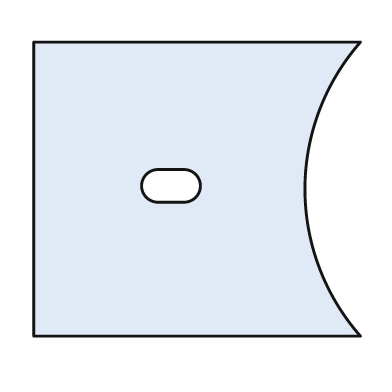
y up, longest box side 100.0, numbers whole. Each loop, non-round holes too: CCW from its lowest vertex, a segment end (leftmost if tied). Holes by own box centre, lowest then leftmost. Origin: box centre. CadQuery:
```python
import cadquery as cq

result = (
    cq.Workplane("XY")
    .moveTo(-50.0, -45.0)
    .lineTo(50.0, -45.0)
    .threePointArc((33.0, 0.0), (50.0, 45.0))
    .lineTo(-50.0, 45.0)
    .close()
    .moveTo(-12.0, -4.0)
    .lineTo(-4.0, -4.0)
    .threePointArc((1.0, 1.0), (-4.0, 6.0))
    .lineTo(-12.0, 6.0)
    .threePointArc((-17.0, 1.0), (-12.0, -4.0))
    .close()
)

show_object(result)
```